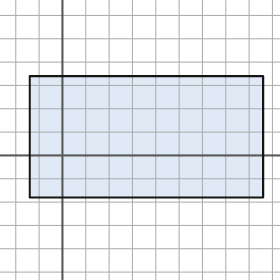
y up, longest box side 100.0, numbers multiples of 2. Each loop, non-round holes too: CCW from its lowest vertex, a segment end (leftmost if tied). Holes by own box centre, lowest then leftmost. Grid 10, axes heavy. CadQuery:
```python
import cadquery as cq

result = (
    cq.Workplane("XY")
    .moveTo(-14.0, -18.0)
    .lineTo(86.0, -18.0)
    .lineTo(86.0, 34.0)
    .lineTo(-14.0, 34.0)
    .close()
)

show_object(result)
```